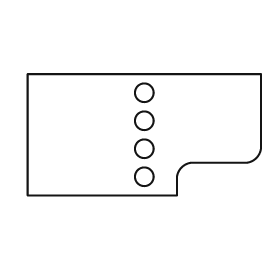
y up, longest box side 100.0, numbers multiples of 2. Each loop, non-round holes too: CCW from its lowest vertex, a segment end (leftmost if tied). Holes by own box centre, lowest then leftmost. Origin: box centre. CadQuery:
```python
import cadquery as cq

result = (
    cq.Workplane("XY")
    .moveTo(-50.0, -26.0)
    .lineTo(14.0, -26.0)
    .lineTo(14.0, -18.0)
    .threePointArc((16.0, -14.0), (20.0, -12.0))
    .lineTo(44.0, -12.0)
    .threePointArc((48.0, -10.0), (50.0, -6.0))
    .lineTo(50.0, 26.0)
    .lineTo(-50.0, 26.0)
    .close()
    .moveTo(0.0, -18.0)
    .circle(4.0)
    .moveTo(0.0, -6.0)
    .circle(4.0)
    .moveTo(0.0, 6.0)
    .circle(4.0)
    .moveTo(0.0, 18.0)
    .circle(4.0)
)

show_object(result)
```